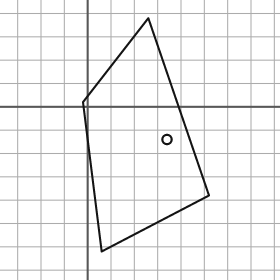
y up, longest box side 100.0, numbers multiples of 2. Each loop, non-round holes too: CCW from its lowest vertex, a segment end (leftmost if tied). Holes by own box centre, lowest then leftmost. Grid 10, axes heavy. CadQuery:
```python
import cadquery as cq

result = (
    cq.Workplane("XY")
    .moveTo(6.0, -62.0)
    .lineTo(52.0, -38.0)
    .lineTo(26.0, 38.0)
    .lineTo(-2.0, 2.0)
    .close()
    .moveTo(34.0, -14.0)
    .circle(2.0)
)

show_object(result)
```